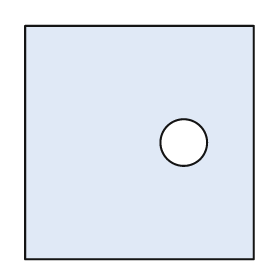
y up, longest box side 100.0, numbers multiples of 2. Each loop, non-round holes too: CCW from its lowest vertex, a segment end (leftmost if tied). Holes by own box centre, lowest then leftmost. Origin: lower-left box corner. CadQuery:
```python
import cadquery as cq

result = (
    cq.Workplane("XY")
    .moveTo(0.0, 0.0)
    .lineTo(98.0, 0.0)
    .lineTo(98.0, 100.0)
    .lineTo(0.0, 100.0)
    .close()
    .moveTo(68.0, 50.0)
    .circle(10.0)
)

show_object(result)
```